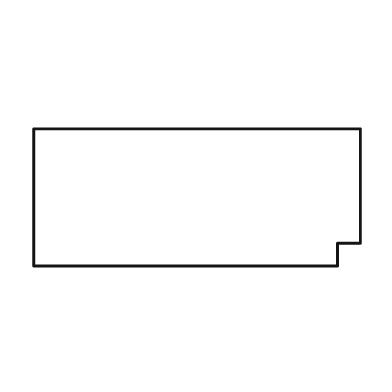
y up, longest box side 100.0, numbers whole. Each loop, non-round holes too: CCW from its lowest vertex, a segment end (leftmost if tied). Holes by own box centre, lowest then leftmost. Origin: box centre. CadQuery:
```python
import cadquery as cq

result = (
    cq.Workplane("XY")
    .moveTo(-50.0, -21.0)
    .lineTo(43.0, -21.0)
    .lineTo(43.0, -14.0)
    .lineTo(50.0, -14.0)
    .lineTo(50.0, 21.0)
    .lineTo(-50.0, 21.0)
    .close()
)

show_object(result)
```